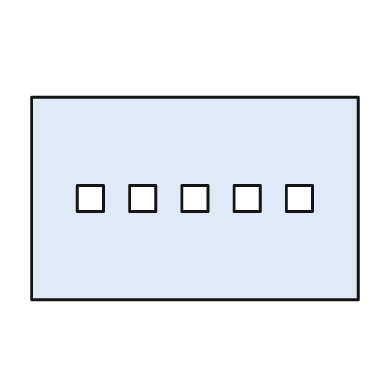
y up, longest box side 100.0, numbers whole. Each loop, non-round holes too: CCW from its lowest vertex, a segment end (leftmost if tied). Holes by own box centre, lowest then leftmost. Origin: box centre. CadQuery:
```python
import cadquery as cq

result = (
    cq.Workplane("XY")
    .moveTo(-50.0, -31.0)
    .lineTo(50.0, -31.0)
    .lineTo(50.0, 31.0)
    .lineTo(-50.0, 31.0)
    .close()
    .moveTo(-36.0, -4.0)
    .lineTo(-28.0, -4.0)
    .lineTo(-28.0, 4.0)
    .lineTo(-36.0, 4.0)
    .close()
    .moveTo(-20.0, -4.0)
    .lineTo(-12.0, -4.0)
    .lineTo(-12.0, 4.0)
    .lineTo(-20.0, 4.0)
    .close()
    .moveTo(-4.0, -4.0)
    .lineTo(4.0, -4.0)
    .lineTo(4.0, 4.0)
    .lineTo(-4.0, 4.0)
    .close()
    .moveTo(12.0, -4.0)
    .lineTo(20.0, -4.0)
    .lineTo(20.0, 4.0)
    .lineTo(12.0, 4.0)
    .close()
    .moveTo(28.0, -4.0)
    .lineTo(36.0, -4.0)
    .lineTo(36.0, 4.0)
    .lineTo(28.0, 4.0)
    .close()
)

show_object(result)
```